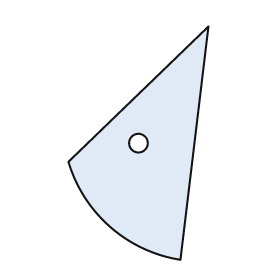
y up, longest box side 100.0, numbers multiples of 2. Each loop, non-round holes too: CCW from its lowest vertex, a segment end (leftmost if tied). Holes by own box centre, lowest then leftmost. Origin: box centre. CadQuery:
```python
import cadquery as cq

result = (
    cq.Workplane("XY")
    .moveTo(18.0, -50.0)
    .lineTo(30.0, 50.0)
    .lineTo(-30.0, -8.0)
    .threePointArc((-12.0, -36.0), (18.0, -50.0))
    .close()
    .moveTo(0.0, 0.0)
    .circle(4.0)
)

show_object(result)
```